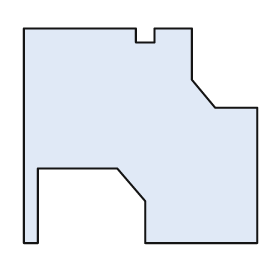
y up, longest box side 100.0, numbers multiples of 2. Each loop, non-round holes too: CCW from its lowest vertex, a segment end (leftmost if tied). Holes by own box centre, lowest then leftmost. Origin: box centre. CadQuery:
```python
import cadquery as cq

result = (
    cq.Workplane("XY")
    .moveTo(-50.0, -46.0)
    .lineTo(-44.0, -46.0)
    .lineTo(-44.0, -14.0)
    .lineTo(-10.0, -14.0)
    .lineTo(2.0, -28.0)
    .lineTo(2.0, -46.0)
    .lineTo(50.0, -46.0)
    .lineTo(50.0, 12.0)
    .lineTo(32.0, 12.0)
    .lineTo(22.0, 24.0)
    .lineTo(22.0, 46.0)
    .lineTo(6.0, 46.0)
    .lineTo(6.0, 40.0)
    .lineTo(-2.0, 40.0)
    .lineTo(-2.0, 46.0)
    .lineTo(-50.0, 46.0)
    .close()
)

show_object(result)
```